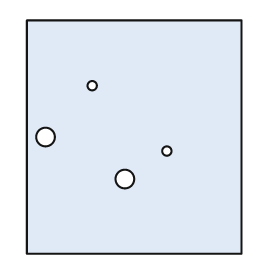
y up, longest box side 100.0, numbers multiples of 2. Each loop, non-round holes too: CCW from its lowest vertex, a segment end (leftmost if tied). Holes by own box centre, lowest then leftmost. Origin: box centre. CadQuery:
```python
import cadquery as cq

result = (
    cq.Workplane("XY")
    .moveTo(-46.0, -50.0)
    .lineTo(46.0, -50.0)
    .lineTo(46.0, 50.0)
    .lineTo(-46.0, 50.0)
    .close()
    .moveTo(-4.0, -18.0)
    .circle(4.0)
    .moveTo(14.0, -6.0)
    .circle(2.0)
    .moveTo(-38.0, 0.0)
    .circle(4.0)
    .moveTo(-18.0, 22.0)
    .circle(2.0)
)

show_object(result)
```